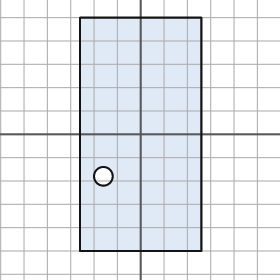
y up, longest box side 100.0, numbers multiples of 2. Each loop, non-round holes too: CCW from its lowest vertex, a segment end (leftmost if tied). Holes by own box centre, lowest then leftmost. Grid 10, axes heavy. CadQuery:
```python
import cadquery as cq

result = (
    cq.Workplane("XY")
    .moveTo(-26.0, -50.0)
    .lineTo(26.0, -50.0)
    .lineTo(26.0, 50.0)
    .lineTo(-26.0, 50.0)
    .close()
    .moveTo(-16.0, -18.0)
    .circle(4.0)
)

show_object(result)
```